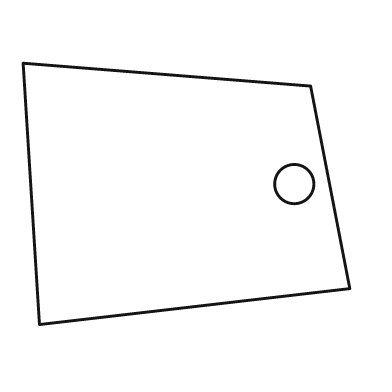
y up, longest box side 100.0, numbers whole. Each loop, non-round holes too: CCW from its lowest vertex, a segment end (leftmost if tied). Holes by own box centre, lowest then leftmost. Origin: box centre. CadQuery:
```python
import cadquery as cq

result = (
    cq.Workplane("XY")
    .moveTo(-45.0, -40.0)
    .lineTo(50.0, -29.0)
    .lineTo(38.0, 33.0)
    .lineTo(-50.0, 40.0)
    .close()
    .moveTo(33.0, 3.0)
    .circle(6.0)
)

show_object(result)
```